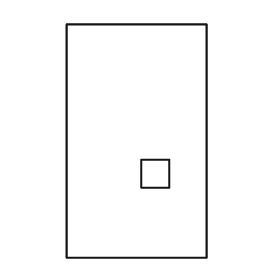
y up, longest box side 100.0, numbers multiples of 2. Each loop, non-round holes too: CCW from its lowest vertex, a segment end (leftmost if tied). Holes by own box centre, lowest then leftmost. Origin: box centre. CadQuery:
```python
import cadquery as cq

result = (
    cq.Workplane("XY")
    .moveTo(-30.0, -50.0)
    .lineTo(30.0, -50.0)
    .lineTo(30.0, 50.0)
    .lineTo(-30.0, 50.0)
    .close()
    .moveTo(2.0, -20.0)
    .lineTo(14.0, -20.0)
    .lineTo(14.0, -8.0)
    .lineTo(2.0, -8.0)
    .close()
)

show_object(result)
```